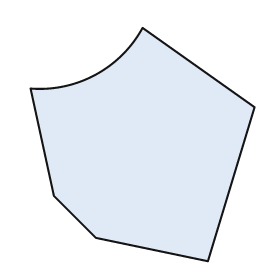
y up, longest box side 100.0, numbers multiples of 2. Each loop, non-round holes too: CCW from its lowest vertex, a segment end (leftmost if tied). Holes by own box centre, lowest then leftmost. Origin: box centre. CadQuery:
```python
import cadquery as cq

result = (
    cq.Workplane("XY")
    .moveTo(28.0, -50.0)
    .lineTo(48.0, 16.0)
    .lineTo(0.0, 50.0)
    .threePointArc((-20.0, 30.0), (-48.0, 24.0))
    .lineTo(-38.0, -22.0)
    .lineTo(-20.0, -40.0)
    .close()
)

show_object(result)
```